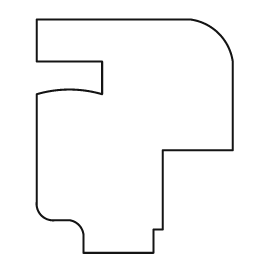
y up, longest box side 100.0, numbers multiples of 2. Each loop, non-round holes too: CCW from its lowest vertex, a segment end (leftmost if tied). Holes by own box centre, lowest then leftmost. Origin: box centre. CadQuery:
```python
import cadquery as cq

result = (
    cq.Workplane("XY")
    .moveTo(-22.0, -50.0)
    .lineTo(8.0, -50.0)
    .lineTo(8.0, -40.0)
    .lineTo(12.0, -40.0)
    .lineTo(12.0, -6.0)
    .lineTo(42.0, -6.0)
    .lineTo(42.0, 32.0)
    .threePointArc((36.0, 44.0), (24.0, 50.0))
    .lineTo(-42.0, 50.0)
    .lineTo(-42.0, 32.0)
    .lineTo(-14.0, 32.0)
    .lineTo(-14.0, 18.0)
    .threePointArc((-28.0, 20.0), (-42.0, 18.0))
    .lineTo(-42.0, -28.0)
    .threePointArc((-40.0, -34.0), (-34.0, -36.0))
    .lineTo(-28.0, -36.0)
    .threePointArc((-24.0, -38.0), (-22.0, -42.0))
    .close()
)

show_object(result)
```